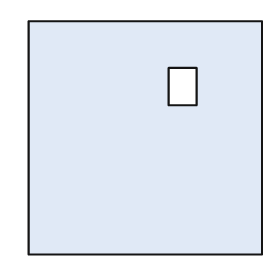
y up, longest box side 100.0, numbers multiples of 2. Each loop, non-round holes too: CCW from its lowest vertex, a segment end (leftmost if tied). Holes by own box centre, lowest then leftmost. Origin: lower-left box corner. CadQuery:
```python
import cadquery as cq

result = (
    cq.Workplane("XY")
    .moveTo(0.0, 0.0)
    .lineTo(100.0, 0.0)
    .lineTo(100.0, 100.0)
    .lineTo(0.0, 100.0)
    .close()
    .moveTo(60.0, 64.0)
    .lineTo(72.0, 64.0)
    .lineTo(72.0, 80.0)
    .lineTo(60.0, 80.0)
    .close()
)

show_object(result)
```